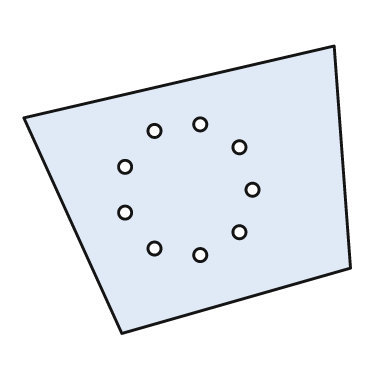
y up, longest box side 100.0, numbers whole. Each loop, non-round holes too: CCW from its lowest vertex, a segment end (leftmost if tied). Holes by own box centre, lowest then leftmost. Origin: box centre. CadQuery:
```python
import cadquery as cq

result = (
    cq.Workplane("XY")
    .moveTo(-20.0, -44.0)
    .lineTo(50.0, -24.0)
    .lineTo(45.0, 44.0)
    .lineTo(-50.0, 22.0)
    .close()
    .moveTo(4.0, -20.0)
    .circle(2.0)
    .moveTo(-10.0, -18.0)
    .circle(2.0)
    .moveTo(16.0, -13.0)
    .circle(2.0)
    .moveTo(-19.0, -7.0)
    .circle(2.0)
    .moveTo(20.0, 0.0)
    .circle(2.0)
    .moveTo(-19.0, 7.0)
    .circle(2.0)
    .moveTo(16.0, 13.0)
    .circle(2.0)
    .moveTo(-10.0, 18.0)
    .circle(2.0)
    .moveTo(4.0, 20.0)
    .circle(2.0)
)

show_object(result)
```